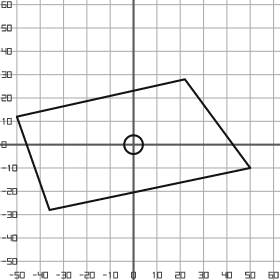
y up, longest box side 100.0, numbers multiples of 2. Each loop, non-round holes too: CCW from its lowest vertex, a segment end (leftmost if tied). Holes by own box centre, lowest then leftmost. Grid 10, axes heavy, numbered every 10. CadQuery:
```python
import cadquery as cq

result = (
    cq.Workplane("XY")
    .moveTo(-36.0, -28.0)
    .lineTo(50.0, -10.0)
    .lineTo(22.0, 28.0)
    .lineTo(-50.0, 12.0)
    .close()
    .moveTo(0.0, 0.0)
    .circle(4.0)
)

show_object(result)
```